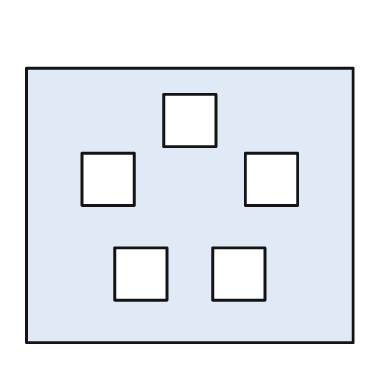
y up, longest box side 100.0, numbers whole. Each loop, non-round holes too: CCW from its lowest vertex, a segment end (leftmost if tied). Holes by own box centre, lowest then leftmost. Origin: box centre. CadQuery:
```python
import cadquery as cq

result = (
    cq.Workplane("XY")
    .moveTo(-50.0, -42.0)
    .lineTo(50.0, -42.0)
    .lineTo(50.0, 42.0)
    .lineTo(-50.0, 42.0)
    .close()
    .moveTo(-23.0, -29.0)
    .lineTo(-7.0, -29.0)
    .lineTo(-7.0, -13.0)
    .lineTo(-23.0, -13.0)
    .close()
    .moveTo(7.0, -29.0)
    .lineTo(23.0, -29.0)
    .lineTo(23.0, -13.0)
    .lineTo(7.0, -13.0)
    .close()
    .moveTo(-33.0, 0.0)
    .lineTo(-17.0, 0.0)
    .lineTo(-17.0, 16.0)
    .lineTo(-33.0, 16.0)
    .close()
    .moveTo(17.0, 0.0)
    .lineTo(33.0, 0.0)
    .lineTo(33.0, 16.0)
    .lineTo(17.0, 16.0)
    .close()
    .moveTo(-8.0, 18.0)
    .lineTo(8.0, 18.0)
    .lineTo(8.0, 34.0)
    .lineTo(-8.0, 34.0)
    .close()
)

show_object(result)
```